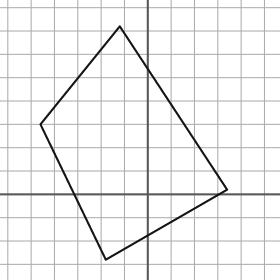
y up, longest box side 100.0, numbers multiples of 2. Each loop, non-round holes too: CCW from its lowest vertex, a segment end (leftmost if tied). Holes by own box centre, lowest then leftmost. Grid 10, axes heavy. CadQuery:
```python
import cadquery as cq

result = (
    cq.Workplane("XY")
    .moveTo(-18.0, -28.0)
    .lineTo(34.0, 2.0)
    .lineTo(-12.0, 72.0)
    .lineTo(-46.0, 30.0)
    .close()
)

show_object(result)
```